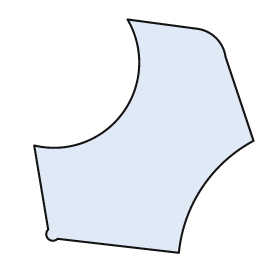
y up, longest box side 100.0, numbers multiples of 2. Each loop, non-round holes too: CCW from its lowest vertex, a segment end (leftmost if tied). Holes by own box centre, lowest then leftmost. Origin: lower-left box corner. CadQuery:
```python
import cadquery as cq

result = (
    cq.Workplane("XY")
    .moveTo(62.0, 0.0)
    .threePointArc((72.0, 28.0), (94.0, 48.0))
    .lineTo(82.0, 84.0)
    .threePointArc((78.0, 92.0), (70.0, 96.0))
    .lineTo(40.0, 100.0)
    .threePointArc((38.0, 60.0), (0.0, 46.0))
    .lineTo(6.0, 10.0)
    .threePointArc((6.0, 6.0), (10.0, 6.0))
    .close()
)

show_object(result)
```